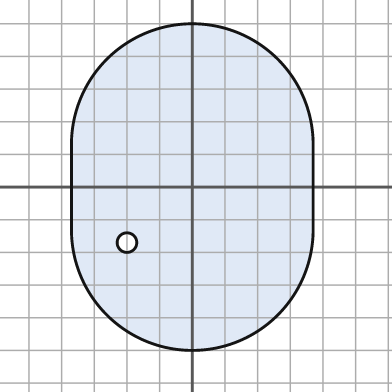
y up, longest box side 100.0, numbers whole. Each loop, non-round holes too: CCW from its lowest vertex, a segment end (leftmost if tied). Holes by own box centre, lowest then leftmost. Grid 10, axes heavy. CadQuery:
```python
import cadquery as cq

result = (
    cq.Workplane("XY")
    .moveTo(-37.0, -13.0)
    .threePointArc((0.0, -50.0), (37.0, -13.0))
    .lineTo(37.0, 13.0)
    .threePointArc((0.0, 50.0), (-37.0, 13.0))
    .close()
    .moveTo(-20.0, -17.0)
    .circle(3.0)
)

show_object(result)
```